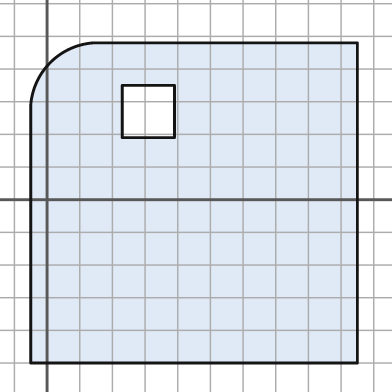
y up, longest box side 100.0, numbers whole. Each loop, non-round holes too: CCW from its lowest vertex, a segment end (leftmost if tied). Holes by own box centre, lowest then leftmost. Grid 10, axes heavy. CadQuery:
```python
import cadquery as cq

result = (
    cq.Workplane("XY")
    .moveTo(-5.0, -50.0)
    .lineTo(95.0, -50.0)
    .lineTo(95.0, 48.0)
    .lineTo(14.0, 48.0)
    .threePointArc((1.0, 42.0), (-5.0, 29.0))
    .close()
    .moveTo(23.0, 19.0)
    .lineTo(39.0, 19.0)
    .lineTo(39.0, 35.0)
    .lineTo(23.0, 35.0)
    .close()
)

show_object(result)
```